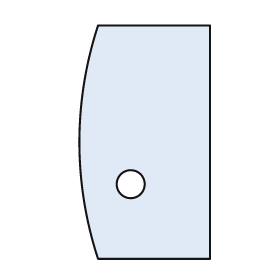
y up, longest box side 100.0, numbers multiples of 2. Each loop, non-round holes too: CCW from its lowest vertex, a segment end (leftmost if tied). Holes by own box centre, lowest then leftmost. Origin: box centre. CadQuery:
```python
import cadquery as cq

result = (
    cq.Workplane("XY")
    .moveTo(-20.0, -50.0)
    .lineTo(28.0, -50.0)
    .lineTo(28.0, 50.0)
    .lineTo(-20.0, 50.0)
    .threePointArc((-28.0, 0.0), (-20.0, -50.0))
    .close()
    .moveTo(-6.0, -18.0)
    .circle(6.0)
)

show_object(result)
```